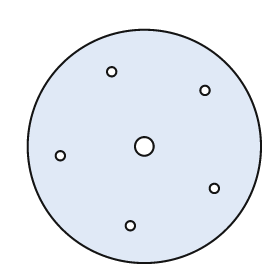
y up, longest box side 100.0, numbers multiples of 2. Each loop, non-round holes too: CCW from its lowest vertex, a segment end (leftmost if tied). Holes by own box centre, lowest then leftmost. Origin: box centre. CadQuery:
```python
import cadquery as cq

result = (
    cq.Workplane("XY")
    .moveTo(0.0, 0.0)
    .circle(50.0)
    .moveTo(-6.0, -34.0)
    .circle(2.0)
    .moveTo(30.0, -18.0)
    .circle(2.0)
    .moveTo(-36.0, -4.0)
    .circle(2.0)
    .moveTo(0.0, 0.0)
    .circle(4.0)
    .moveTo(26.0, 24.0)
    .circle(2.0)
    .moveTo(-14.0, 32.0)
    .circle(2.0)
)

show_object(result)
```